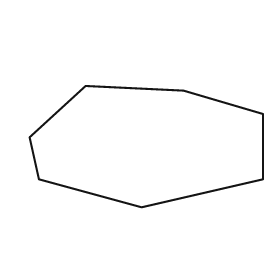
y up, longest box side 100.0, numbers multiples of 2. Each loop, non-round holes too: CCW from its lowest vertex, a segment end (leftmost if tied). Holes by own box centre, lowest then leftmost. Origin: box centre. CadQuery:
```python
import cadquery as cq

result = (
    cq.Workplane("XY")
    .moveTo(-2.0, -26.0)
    .lineTo(50.0, -14.0)
    .lineTo(50.0, 14.0)
    .lineTo(16.0, 24.0)
    .lineTo(-26.0, 26.0)
    .lineTo(-50.0, 4.0)
    .lineTo(-46.0, -14.0)
    .close()
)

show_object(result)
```